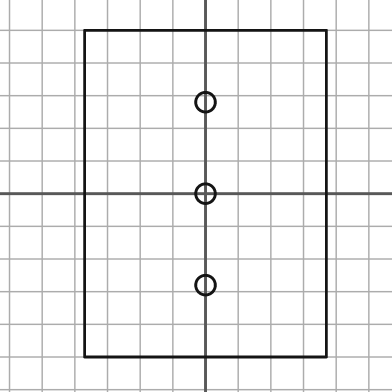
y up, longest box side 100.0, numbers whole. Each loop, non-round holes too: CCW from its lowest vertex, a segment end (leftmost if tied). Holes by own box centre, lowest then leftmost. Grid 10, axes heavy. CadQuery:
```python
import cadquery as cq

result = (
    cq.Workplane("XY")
    .moveTo(-37.0, -50.0)
    .lineTo(37.0, -50.0)
    .lineTo(37.0, 50.0)
    .lineTo(-37.0, 50.0)
    .close()
    .moveTo(0.0, -28.0)
    .circle(3.0)
    .moveTo(0.0, 0.0)
    .circle(3.0)
    .moveTo(0.0, 28.0)
    .circle(3.0)
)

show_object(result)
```